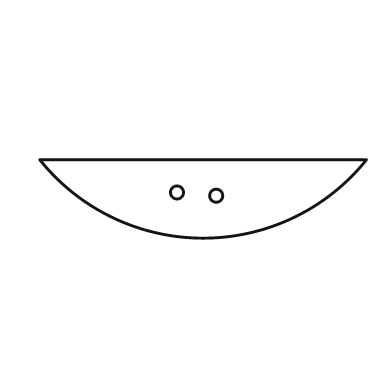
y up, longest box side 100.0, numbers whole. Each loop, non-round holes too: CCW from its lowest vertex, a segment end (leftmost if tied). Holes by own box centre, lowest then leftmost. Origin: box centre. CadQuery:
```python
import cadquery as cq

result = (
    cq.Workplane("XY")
    .moveTo(-50.0, 12.0)
    .threePointArc((0.0, -12.0), (50.0, 12.0))
    .close()
    .moveTo(4.0, 1.0)
    .circle(2.0)
    .moveTo(-8.0, 2.0)
    .circle(2.0)
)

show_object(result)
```